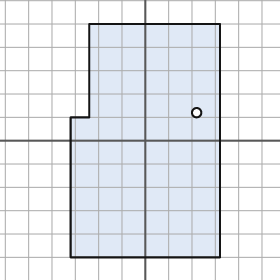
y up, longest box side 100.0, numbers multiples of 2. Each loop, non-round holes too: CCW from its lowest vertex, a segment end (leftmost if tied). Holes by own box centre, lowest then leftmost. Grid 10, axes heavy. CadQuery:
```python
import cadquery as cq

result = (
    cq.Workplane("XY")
    .moveTo(-32.0, -50.0)
    .lineTo(32.0, -50.0)
    .lineTo(32.0, 50.0)
    .lineTo(-24.0, 50.0)
    .lineTo(-24.0, 10.0)
    .lineTo(-32.0, 10.0)
    .close()
    .moveTo(22.0, 12.0)
    .circle(2.0)
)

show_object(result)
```